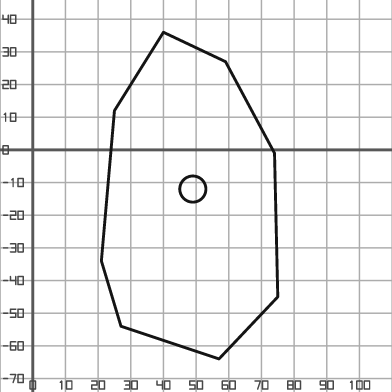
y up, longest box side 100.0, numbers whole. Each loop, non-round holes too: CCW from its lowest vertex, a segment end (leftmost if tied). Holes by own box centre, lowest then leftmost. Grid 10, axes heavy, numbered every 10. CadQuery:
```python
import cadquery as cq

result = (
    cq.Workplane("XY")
    .moveTo(57.0, -64.0)
    .lineTo(75.0, -45.0)
    .lineTo(74.0, -1.0)
    .lineTo(59.0, 27.0)
    .lineTo(40.0, 36.0)
    .lineTo(25.0, 12.0)
    .lineTo(21.0, -34.0)
    .lineTo(27.0, -54.0)
    .close()
    .moveTo(49.0, -12.0)
    .circle(4.0)
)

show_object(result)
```